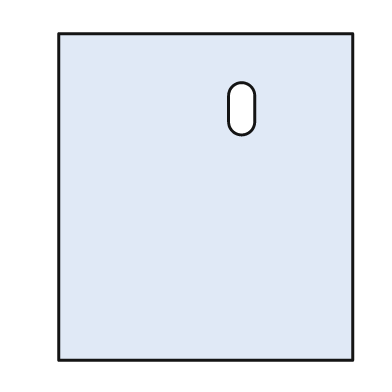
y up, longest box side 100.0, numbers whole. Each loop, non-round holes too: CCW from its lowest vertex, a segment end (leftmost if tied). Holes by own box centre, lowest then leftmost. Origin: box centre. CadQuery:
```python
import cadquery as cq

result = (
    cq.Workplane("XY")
    .moveTo(-45.0, -50.0)
    .lineTo(45.0, -50.0)
    .lineTo(45.0, 50.0)
    .lineTo(-45.0, 50.0)
    .close()
    .moveTo(7.0, 23.0)
    .threePointArc((11.0, 19.0), (15.0, 23.0))
    .lineTo(15.0, 31.0)
    .threePointArc((11.0, 35.0), (7.0, 31.0))
    .close()
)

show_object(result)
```